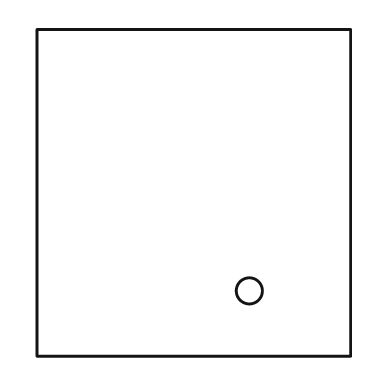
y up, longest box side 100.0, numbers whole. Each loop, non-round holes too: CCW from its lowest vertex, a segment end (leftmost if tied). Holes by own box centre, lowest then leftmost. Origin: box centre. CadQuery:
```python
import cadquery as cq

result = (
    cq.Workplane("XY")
    .moveTo(-48.0, -50.0)
    .lineTo(48.0, -50.0)
    .lineTo(48.0, 50.0)
    .lineTo(-48.0, 50.0)
    .close()
    .moveTo(17.0, -30.0)
    .circle(4.0)
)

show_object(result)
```